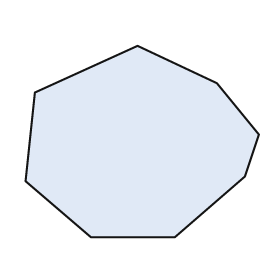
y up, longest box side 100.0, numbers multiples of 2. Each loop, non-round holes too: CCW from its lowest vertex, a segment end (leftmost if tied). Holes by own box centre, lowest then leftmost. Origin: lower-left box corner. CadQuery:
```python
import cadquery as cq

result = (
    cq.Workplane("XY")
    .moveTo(28.0, 0.0)
    .lineTo(64.0, 0.0)
    .lineTo(94.0, 26.0)
    .lineTo(100.0, 44.0)
    .lineTo(82.0, 66.0)
    .lineTo(48.0, 82.0)
    .lineTo(4.0, 62.0)
    .lineTo(0.0, 24.0)
    .close()
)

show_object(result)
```